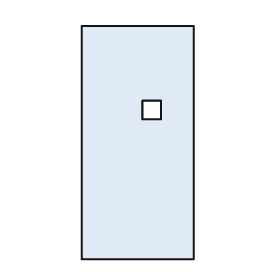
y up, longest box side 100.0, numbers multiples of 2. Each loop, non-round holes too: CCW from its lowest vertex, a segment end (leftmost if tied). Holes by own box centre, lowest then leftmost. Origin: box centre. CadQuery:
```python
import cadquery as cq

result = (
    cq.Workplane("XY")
    .moveTo(-24.0, -50.0)
    .lineTo(24.0, -50.0)
    .lineTo(24.0, 50.0)
    .lineTo(-24.0, 50.0)
    .close()
    .moveTo(2.0, 10.0)
    .lineTo(10.0, 10.0)
    .lineTo(10.0, 18.0)
    .lineTo(2.0, 18.0)
    .close()
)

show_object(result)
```